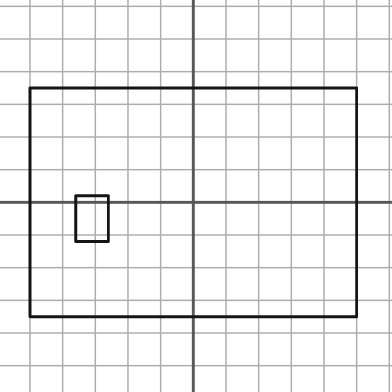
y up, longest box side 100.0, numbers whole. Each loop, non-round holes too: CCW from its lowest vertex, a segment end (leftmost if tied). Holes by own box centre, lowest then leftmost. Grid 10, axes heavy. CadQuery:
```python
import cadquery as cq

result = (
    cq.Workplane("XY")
    .moveTo(-50.0, -35.0)
    .lineTo(50.0, -35.0)
    .lineTo(50.0, 35.0)
    .lineTo(-50.0, 35.0)
    .close()
    .moveTo(-36.0, -12.0)
    .lineTo(-26.0, -12.0)
    .lineTo(-26.0, 2.0)
    .lineTo(-36.0, 2.0)
    .close()
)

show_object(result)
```